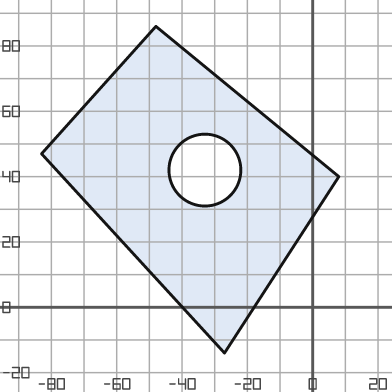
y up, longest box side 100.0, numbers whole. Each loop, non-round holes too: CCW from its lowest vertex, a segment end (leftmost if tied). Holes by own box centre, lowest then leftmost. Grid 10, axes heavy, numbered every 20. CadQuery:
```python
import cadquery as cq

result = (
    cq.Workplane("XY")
    .moveTo(-27.0, -14.0)
    .lineTo(8.0, 40.0)
    .lineTo(-48.0, 86.0)
    .lineTo(-83.0, 47.0)
    .close()
    .moveTo(-33.0, 42.0)
    .circle(11.0)
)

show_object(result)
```